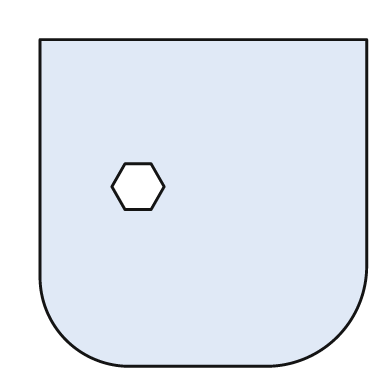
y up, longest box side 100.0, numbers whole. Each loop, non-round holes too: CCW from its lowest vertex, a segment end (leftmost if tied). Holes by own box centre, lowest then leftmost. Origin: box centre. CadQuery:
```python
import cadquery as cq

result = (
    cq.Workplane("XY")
    .moveTo(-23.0, -50.0)
    .lineTo(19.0, -50.0)
    .threePointArc((41.0, -41.0), (50.0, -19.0))
    .lineTo(50.0, 50.0)
    .lineTo(-50.0, 50.0)
    .lineTo(-50.0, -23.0)
    .threePointArc((-42.0, -42.0), (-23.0, -50.0))
    .close()
    .moveTo(-24.0, -2.0)
    .lineTo(-16.0, -2.0)
    .lineTo(-12.0, 5.0)
    .lineTo(-16.0, 12.0)
    .lineTo(-24.0, 12.0)
    .lineTo(-28.0, 5.0)
    .close()
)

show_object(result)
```